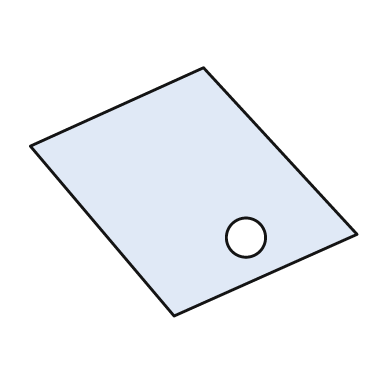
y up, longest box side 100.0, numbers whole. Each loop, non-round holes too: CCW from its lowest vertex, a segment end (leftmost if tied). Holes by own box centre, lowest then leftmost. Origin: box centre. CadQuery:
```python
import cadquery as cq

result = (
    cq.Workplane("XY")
    .moveTo(-6.0, -38.0)
    .lineTo(50.0, -13.0)
    .lineTo(3.0, 38.0)
    .lineTo(-50.0, 14.0)
    .close()
    .moveTo(16.0, -14.0)
    .circle(6.0)
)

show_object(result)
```